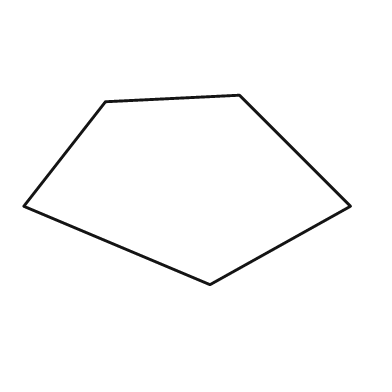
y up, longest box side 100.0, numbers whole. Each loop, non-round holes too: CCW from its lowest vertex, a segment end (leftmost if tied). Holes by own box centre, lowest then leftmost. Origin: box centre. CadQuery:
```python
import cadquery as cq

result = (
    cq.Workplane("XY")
    .moveTo(7.0, -29.0)
    .lineTo(50.0, -5.0)
    .lineTo(16.0, 29.0)
    .lineTo(-25.0, 27.0)
    .lineTo(-50.0, -5.0)
    .close()
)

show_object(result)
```